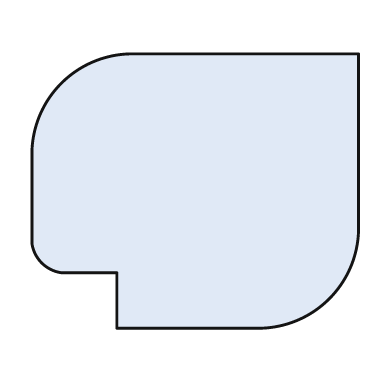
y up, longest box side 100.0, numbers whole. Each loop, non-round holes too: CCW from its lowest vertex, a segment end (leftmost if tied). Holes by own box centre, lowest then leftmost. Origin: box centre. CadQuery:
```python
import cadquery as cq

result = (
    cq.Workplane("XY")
    .moveTo(-24.0, -42.0)
    .lineTo(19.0, -42.0)
    .threePointArc((41.0, -33.0), (50.0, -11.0))
    .lineTo(50.0, 42.0)
    .lineTo(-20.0, 42.0)
    .threePointArc((-41.0, 33.0), (-50.0, 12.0))
    .lineTo(-50.0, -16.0)
    .threePointArc((-47.0, -22.0), (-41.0, -25.0))
    .lineTo(-24.0, -25.0)
    .close()
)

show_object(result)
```